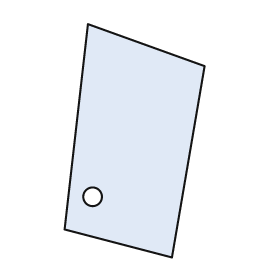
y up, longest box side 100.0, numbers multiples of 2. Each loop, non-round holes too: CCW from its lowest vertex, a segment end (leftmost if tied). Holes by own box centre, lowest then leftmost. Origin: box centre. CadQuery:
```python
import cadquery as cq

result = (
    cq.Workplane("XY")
    .moveTo(16.0, -50.0)
    .lineTo(30.0, 32.0)
    .lineTo(-20.0, 50.0)
    .lineTo(-30.0, -38.0)
    .close()
    .moveTo(-18.0, -24.0)
    .circle(4.0)
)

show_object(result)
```